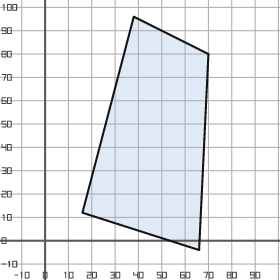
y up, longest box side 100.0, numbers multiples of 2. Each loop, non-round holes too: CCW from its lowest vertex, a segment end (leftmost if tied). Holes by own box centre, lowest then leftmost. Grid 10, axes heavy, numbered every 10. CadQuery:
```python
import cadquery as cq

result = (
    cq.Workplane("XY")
    .moveTo(66.0, -4.0)
    .lineTo(70.0, 80.0)
    .lineTo(38.0, 96.0)
    .lineTo(16.0, 12.0)
    .close()
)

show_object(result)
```